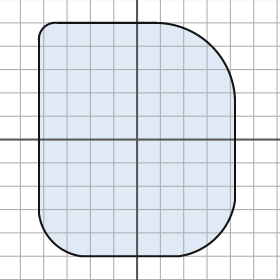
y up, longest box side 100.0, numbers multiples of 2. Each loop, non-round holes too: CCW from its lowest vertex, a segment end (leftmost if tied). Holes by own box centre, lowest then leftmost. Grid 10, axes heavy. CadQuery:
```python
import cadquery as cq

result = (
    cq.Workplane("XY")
    .moveTo(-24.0, -50.0)
    .lineTo(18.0, -50.0)
    .threePointArc((34.0, -42.0), (42.0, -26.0))
    .lineTo(42.0, 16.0)
    .threePointArc((32.0, 40.0), (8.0, 50.0))
    .lineTo(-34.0, 50.0)
    .threePointArc((-40.0, 48.0), (-42.0, 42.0))
    .lineTo(-42.0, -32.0)
    .threePointArc((-36.0, -44.0), (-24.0, -50.0))
    .close()
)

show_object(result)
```